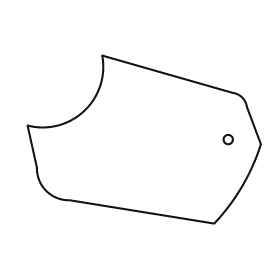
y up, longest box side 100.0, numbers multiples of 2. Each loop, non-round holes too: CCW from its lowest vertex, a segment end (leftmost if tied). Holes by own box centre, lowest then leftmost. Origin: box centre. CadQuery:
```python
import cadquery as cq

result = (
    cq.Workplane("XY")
    .moveTo(30.0, -36.0)
    .threePointArc((42.0, -20.0), (50.0, -2.0))
    .lineTo(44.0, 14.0)
    .threePointArc((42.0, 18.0), (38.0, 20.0))
    .lineTo(-18.0, 36.0)
    .threePointArc((-26.0, 12.0), (-50.0, 6.0))
    .lineTo(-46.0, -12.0)
    .threePointArc((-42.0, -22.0), (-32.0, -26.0))
    .close()
    .moveTo(36.0, 0.0)
    .circle(2.0)
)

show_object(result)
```